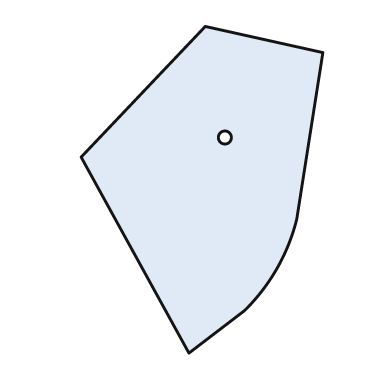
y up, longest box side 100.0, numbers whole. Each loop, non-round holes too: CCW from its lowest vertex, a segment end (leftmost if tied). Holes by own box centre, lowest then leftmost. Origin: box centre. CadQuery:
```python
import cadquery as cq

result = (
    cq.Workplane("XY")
    .moveTo(-4.0, -50.0)
    .lineTo(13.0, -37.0)
    .threePointArc((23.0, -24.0), (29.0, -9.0))
    .lineTo(37.0, 42.0)
    .lineTo(1.0, 50.0)
    .lineTo(-37.0, 10.0)
    .close()
    .moveTo(7.0, 16.0)
    .circle(2.0)
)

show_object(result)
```